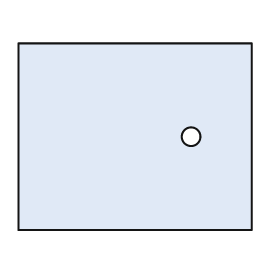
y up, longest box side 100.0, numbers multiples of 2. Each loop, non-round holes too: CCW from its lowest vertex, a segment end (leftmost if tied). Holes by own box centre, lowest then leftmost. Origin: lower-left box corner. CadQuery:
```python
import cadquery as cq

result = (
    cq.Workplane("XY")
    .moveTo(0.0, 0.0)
    .lineTo(100.0, 0.0)
    .lineTo(100.0, 80.0)
    .lineTo(0.0, 80.0)
    .close()
    .moveTo(74.0, 40.0)
    .circle(4.0)
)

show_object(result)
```